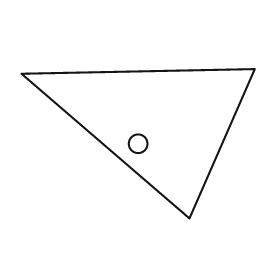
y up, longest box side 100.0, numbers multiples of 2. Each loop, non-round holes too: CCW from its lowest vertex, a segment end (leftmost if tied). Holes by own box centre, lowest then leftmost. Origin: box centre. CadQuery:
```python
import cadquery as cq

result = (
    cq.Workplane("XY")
    .moveTo(22.0, -32.0)
    .lineTo(50.0, 32.0)
    .lineTo(-50.0, 30.0)
    .close()
    .moveTo(0.0, 0.0)
    .circle(4.0)
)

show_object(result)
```